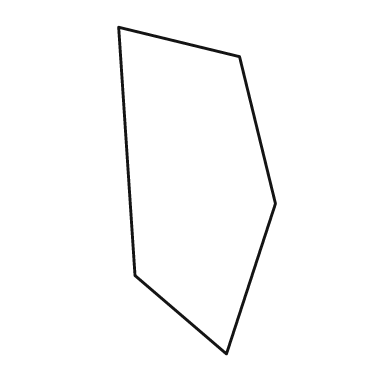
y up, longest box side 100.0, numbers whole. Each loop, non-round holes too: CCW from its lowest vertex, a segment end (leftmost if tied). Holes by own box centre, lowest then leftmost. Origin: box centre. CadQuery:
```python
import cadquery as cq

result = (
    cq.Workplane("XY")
    .moveTo(9.0, -50.0)
    .lineTo(24.0, -4.0)
    .lineTo(13.0, 41.0)
    .lineTo(-24.0, 50.0)
    .lineTo(-19.0, -26.0)
    .close()
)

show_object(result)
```